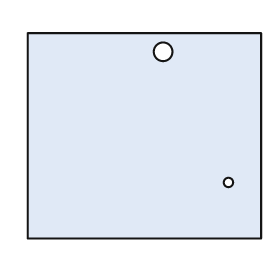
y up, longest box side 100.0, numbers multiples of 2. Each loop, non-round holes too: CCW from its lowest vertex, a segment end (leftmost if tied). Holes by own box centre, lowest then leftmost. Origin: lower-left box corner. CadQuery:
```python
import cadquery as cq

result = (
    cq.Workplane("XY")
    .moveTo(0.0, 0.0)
    .lineTo(100.0, 0.0)
    .lineTo(100.0, 88.0)
    .lineTo(0.0, 88.0)
    .close()
    .moveTo(86.0, 24.0)
    .circle(2.0)
    .moveTo(58.0, 80.0)
    .circle(4.0)
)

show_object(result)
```